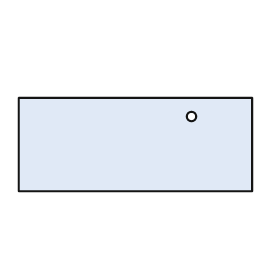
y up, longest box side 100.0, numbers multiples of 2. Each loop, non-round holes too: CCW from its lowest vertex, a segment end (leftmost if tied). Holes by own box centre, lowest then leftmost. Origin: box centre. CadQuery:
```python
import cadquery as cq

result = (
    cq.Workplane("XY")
    .moveTo(-50.0, -20.0)
    .lineTo(50.0, -20.0)
    .lineTo(50.0, 20.0)
    .lineTo(-50.0, 20.0)
    .close()
    .moveTo(24.0, 12.0)
    .circle(2.0)
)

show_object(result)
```